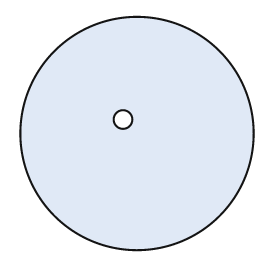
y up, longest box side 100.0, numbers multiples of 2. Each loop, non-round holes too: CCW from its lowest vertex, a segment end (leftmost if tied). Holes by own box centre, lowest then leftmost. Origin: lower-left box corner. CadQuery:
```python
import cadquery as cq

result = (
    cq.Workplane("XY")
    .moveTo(50.0, 50.0)
    .circle(50.0)
    .moveTo(44.0, 56.0)
    .circle(4.0)
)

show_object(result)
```